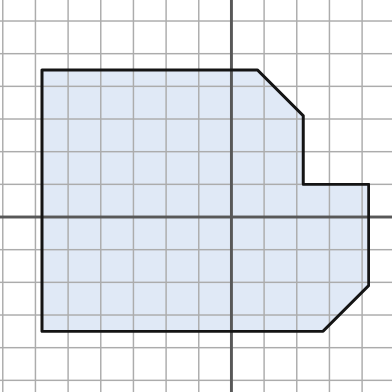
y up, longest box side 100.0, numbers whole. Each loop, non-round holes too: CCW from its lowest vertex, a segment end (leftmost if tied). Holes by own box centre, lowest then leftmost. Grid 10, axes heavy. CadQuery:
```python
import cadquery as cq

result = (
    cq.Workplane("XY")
    .moveTo(-58.0, -35.0)
    .lineTo(28.0, -35.0)
    .lineTo(42.0, -21.0)
    .lineTo(42.0, 10.0)
    .lineTo(22.0, 10.0)
    .lineTo(22.0, 31.0)
    .lineTo(8.0, 45.0)
    .lineTo(-58.0, 45.0)
    .close()
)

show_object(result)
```